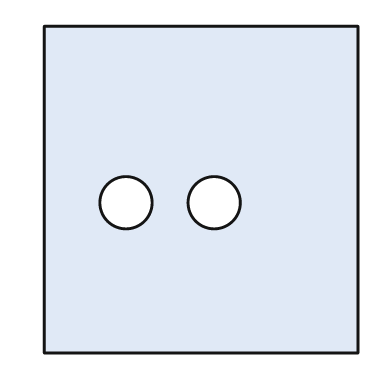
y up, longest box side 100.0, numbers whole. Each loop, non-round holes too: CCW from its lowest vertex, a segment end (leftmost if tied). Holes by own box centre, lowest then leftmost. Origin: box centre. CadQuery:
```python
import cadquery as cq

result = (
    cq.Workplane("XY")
    .moveTo(-48.0, -50.0)
    .lineTo(48.0, -50.0)
    .lineTo(48.0, 50.0)
    .lineTo(-48.0, 50.0)
    .close()
    .moveTo(-23.0, -4.0)
    .circle(8.0)
    .moveTo(4.0, -4.0)
    .circle(8.0)
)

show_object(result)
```